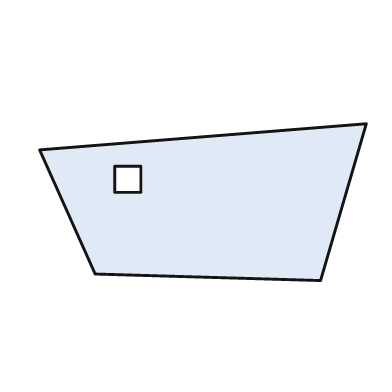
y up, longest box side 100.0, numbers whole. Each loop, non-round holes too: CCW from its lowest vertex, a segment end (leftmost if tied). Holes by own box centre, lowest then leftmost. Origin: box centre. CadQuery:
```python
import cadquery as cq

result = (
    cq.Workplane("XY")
    .moveTo(36.0, -24.0)
    .lineTo(50.0, 24.0)
    .lineTo(-50.0, 16.0)
    .lineTo(-33.0, -22.0)
    .close()
    .moveTo(-27.0, 3.0)
    .lineTo(-19.0, 3.0)
    .lineTo(-19.0, 11.0)
    .lineTo(-27.0, 11.0)
    .close()
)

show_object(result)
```